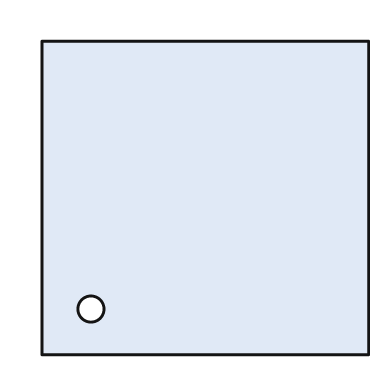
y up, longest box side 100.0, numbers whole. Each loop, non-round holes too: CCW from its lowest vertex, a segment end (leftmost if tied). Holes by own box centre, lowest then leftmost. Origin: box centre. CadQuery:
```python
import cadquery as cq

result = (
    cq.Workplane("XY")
    .moveTo(-50.0, -48.0)
    .lineTo(50.0, -48.0)
    .lineTo(50.0, 48.0)
    .lineTo(-50.0, 48.0)
    .close()
    .moveTo(-35.0, -34.0)
    .circle(4.0)
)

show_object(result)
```